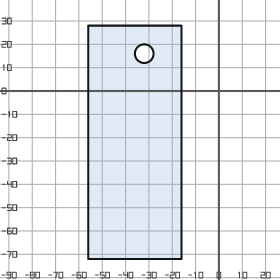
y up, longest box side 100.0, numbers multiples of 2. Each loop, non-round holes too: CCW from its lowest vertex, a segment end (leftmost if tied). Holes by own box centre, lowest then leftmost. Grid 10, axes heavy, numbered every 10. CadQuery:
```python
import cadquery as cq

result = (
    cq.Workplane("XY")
    .moveTo(-56.0, -72.0)
    .lineTo(-16.0, -72.0)
    .lineTo(-16.0, 28.0)
    .lineTo(-56.0, 28.0)
    .close()
    .moveTo(-32.0, 16.0)
    .circle(4.0)
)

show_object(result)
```